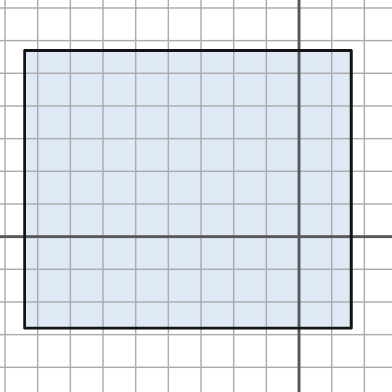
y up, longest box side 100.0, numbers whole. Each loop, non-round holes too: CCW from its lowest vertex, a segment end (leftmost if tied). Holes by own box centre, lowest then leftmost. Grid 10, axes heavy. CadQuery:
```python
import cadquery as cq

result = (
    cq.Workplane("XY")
    .moveTo(-84.0, -28.0)
    .lineTo(16.0, -28.0)
    .lineTo(16.0, 57.0)
    .lineTo(-84.0, 57.0)
    .close()
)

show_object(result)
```